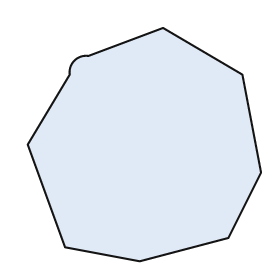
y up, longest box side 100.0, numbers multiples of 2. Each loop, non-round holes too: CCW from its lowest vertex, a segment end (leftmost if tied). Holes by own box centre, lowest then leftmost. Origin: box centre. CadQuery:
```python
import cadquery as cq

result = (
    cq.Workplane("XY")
    .moveTo(-2.0, -50.0)
    .lineTo(36.0, -40.0)
    .lineTo(50.0, -12.0)
    .lineTo(42.0, 30.0)
    .lineTo(8.0, 50.0)
    .lineTo(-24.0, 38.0)
    .threePointArc((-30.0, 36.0), (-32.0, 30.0))
    .lineTo(-50.0, 0.0)
    .lineTo(-34.0, -44.0)
    .close()
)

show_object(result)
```